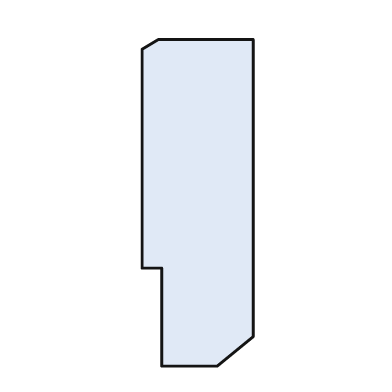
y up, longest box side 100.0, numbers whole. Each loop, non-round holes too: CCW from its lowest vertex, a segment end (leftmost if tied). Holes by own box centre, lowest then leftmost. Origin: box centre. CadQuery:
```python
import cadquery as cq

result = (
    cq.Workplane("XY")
    .moveTo(-11.0, -50.0)
    .lineTo(6.0, -50.0)
    .lineTo(17.0, -41.0)
    .lineTo(17.0, 50.0)
    .lineTo(-12.0, 50.0)
    .lineTo(-17.0, 47.0)
    .lineTo(-17.0, -20.0)
    .lineTo(-11.0, -20.0)
    .close()
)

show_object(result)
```